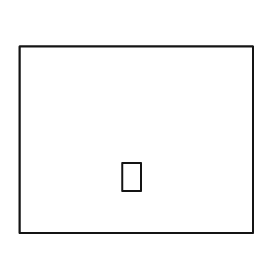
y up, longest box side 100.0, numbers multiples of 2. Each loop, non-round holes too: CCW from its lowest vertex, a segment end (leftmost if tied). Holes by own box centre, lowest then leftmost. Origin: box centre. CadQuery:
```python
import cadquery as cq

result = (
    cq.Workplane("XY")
    .moveTo(-50.0, -40.0)
    .lineTo(50.0, -40.0)
    .lineTo(50.0, 40.0)
    .lineTo(-50.0, 40.0)
    .close()
    .moveTo(-6.0, -22.0)
    .lineTo(2.0, -22.0)
    .lineTo(2.0, -10.0)
    .lineTo(-6.0, -10.0)
    .close()
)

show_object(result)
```